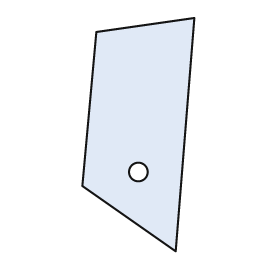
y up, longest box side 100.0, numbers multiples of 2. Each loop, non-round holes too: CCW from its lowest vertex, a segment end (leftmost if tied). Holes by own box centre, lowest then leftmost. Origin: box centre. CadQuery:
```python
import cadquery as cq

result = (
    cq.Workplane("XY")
    .moveTo(16.0, -50.0)
    .lineTo(24.0, 50.0)
    .lineTo(-18.0, 44.0)
    .lineTo(-24.0, -22.0)
    .close()
    .moveTo(0.0, -16.0)
    .circle(4.0)
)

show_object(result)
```